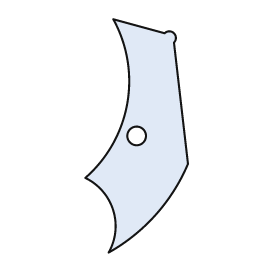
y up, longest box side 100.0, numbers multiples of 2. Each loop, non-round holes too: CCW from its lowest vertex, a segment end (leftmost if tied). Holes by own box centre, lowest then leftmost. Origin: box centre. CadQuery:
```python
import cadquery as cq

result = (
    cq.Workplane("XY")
    .moveTo(-12.0, -50.0)
    .threePointArc((8.0, -34.0), (22.0, -12.0))
    .lineTo(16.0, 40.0)
    .threePointArc((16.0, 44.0), (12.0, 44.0))
    .lineTo(-10.0, 50.0)
    .threePointArc((-4.0, 14.0), (-22.0, -18.0))
    .threePointArc((-10.0, -32.0), (-12.0, -50.0))
    .close()
    .moveTo(0.0, 0.0)
    .circle(4.0)
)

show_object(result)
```